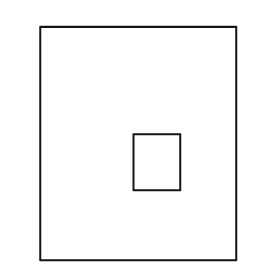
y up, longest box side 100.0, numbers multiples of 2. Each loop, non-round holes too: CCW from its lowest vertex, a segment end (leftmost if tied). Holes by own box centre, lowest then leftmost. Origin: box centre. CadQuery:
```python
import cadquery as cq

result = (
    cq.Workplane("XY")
    .moveTo(-42.0, -50.0)
    .lineTo(42.0, -50.0)
    .lineTo(42.0, 50.0)
    .lineTo(-42.0, 50.0)
    .close()
    .moveTo(-2.0, -20.0)
    .lineTo(18.0, -20.0)
    .lineTo(18.0, 4.0)
    .lineTo(-2.0, 4.0)
    .close()
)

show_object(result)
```